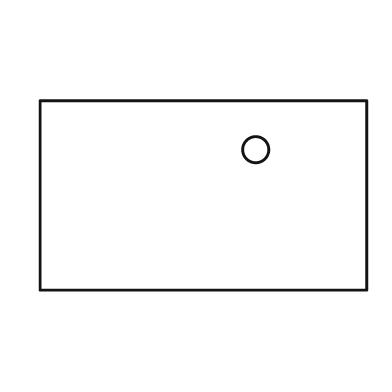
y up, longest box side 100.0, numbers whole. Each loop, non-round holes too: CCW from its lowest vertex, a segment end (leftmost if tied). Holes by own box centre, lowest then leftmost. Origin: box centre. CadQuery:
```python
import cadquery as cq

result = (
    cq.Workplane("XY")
    .moveTo(-50.0, -29.0)
    .lineTo(50.0, -29.0)
    .lineTo(50.0, 29.0)
    .lineTo(-50.0, 29.0)
    .close()
    .moveTo(16.0, 14.0)
    .circle(4.0)
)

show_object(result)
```